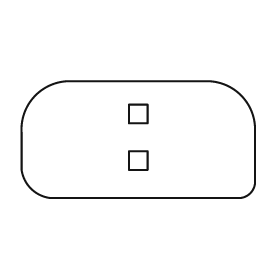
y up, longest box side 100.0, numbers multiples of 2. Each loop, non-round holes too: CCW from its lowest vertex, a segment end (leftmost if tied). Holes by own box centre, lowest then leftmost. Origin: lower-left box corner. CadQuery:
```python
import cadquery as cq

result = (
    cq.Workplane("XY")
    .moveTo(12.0, 0.0)
    .lineTo(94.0, 0.0)
    .threePointArc((98.0, 2.0), (100.0, 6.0))
    .lineTo(100.0, 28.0)
    .threePointArc((94.0, 44.0), (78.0, 50.0))
    .lineTo(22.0, 50.0)
    .threePointArc((6.0, 44.0), (0.0, 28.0))
    .lineTo(0.0, 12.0)
    .threePointArc((4.0, 4.0), (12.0, 0.0))
    .close()
    .moveTo(46.0, 12.0)
    .lineTo(54.0, 12.0)
    .lineTo(54.0, 20.0)
    .lineTo(46.0, 20.0)
    .close()
    .moveTo(46.0, 32.0)
    .lineTo(54.0, 32.0)
    .lineTo(54.0, 40.0)
    .lineTo(46.0, 40.0)
    .close()
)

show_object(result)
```